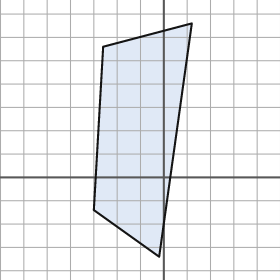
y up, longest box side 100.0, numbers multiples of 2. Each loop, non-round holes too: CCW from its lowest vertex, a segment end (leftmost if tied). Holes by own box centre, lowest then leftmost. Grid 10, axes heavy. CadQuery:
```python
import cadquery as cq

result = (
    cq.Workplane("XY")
    .moveTo(-2.0, -34.0)
    .lineTo(12.0, 66.0)
    .lineTo(-26.0, 56.0)
    .lineTo(-30.0, -14.0)
    .close()
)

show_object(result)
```